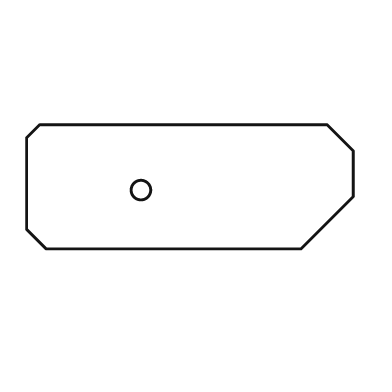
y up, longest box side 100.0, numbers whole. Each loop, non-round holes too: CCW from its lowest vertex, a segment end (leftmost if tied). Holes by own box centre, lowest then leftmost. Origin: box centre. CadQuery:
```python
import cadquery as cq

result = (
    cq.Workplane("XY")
    .moveTo(-44.0, -19.0)
    .lineTo(34.0, -19.0)
    .lineTo(50.0, -3.0)
    .lineTo(50.0, 11.0)
    .lineTo(42.0, 19.0)
    .lineTo(-46.0, 19.0)
    .lineTo(-50.0, 15.0)
    .lineTo(-50.0, -13.0)
    .close()
    .moveTo(-15.0, -1.0)
    .circle(3.0)
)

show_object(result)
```